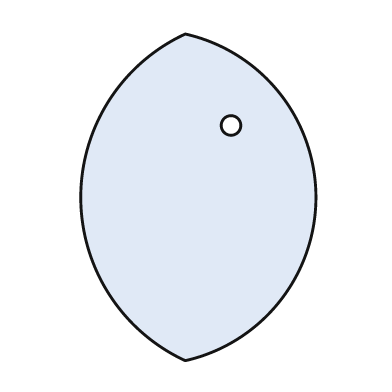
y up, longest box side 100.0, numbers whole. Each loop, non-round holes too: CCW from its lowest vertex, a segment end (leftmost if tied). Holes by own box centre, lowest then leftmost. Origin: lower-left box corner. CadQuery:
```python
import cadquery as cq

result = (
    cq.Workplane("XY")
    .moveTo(32.0, 0.0)
    .threePointArc((72.0, 50.0), (32.0, 100.0))
    .threePointArc((0.0, 50.0), (32.0, 0.0))
    .close()
    .moveTo(46.0, 72.0)
    .circle(3.0)
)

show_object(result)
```